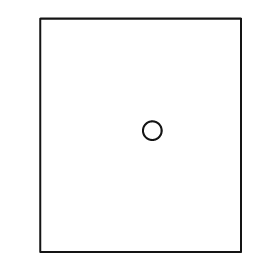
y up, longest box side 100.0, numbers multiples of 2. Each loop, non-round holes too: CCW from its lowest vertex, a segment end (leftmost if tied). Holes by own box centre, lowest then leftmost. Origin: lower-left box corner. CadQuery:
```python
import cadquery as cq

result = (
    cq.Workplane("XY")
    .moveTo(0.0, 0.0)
    .lineTo(86.0, 0.0)
    .lineTo(86.0, 100.0)
    .lineTo(0.0, 100.0)
    .close()
    .moveTo(48.0, 52.0)
    .circle(4.0)
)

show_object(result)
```